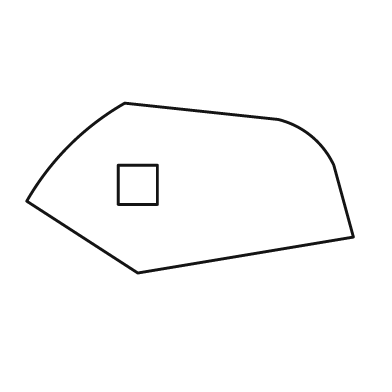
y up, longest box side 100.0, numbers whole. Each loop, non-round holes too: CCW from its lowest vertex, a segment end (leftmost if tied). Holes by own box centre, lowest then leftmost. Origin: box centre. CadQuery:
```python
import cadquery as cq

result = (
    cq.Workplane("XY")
    .moveTo(-16.0, -26.0)
    .lineTo(50.0, -15.0)
    .lineTo(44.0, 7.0)
    .threePointArc((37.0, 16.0), (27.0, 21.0))
    .lineTo(-20.0, 26.0)
    .threePointArc((-37.0, 13.0), (-50.0, -4.0))
    .close()
    .moveTo(-22.0, -5.0)
    .lineTo(-10.0, -5.0)
    .lineTo(-10.0, 7.0)
    .lineTo(-22.0, 7.0)
    .close()
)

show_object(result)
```